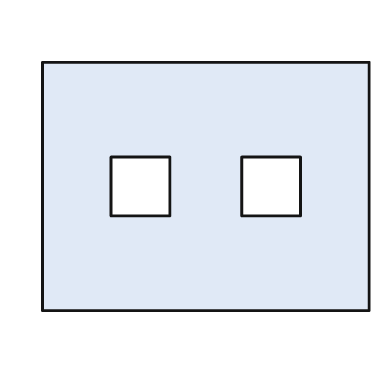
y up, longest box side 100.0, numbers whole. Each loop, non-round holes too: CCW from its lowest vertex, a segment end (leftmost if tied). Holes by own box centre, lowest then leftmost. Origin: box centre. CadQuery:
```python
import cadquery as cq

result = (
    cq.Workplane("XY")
    .moveTo(-50.0, -38.0)
    .lineTo(50.0, -38.0)
    .lineTo(50.0, 38.0)
    .lineTo(-50.0, 38.0)
    .close()
    .moveTo(-29.0, -9.0)
    .lineTo(-11.0, -9.0)
    .lineTo(-11.0, 9.0)
    .lineTo(-29.0, 9.0)
    .close()
    .moveTo(11.0, -9.0)
    .lineTo(29.0, -9.0)
    .lineTo(29.0, 9.0)
    .lineTo(11.0, 9.0)
    .close()
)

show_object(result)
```